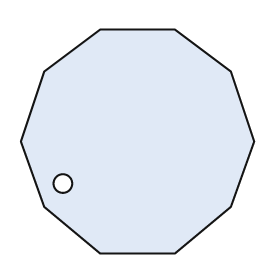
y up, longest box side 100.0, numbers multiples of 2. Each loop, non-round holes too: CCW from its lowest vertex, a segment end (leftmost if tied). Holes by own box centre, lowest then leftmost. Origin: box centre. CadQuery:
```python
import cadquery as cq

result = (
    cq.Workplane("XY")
    .moveTo(-16.0, -48.0)
    .lineTo(16.0, -48.0)
    .lineTo(40.0, -28.0)
    .lineTo(50.0, 0.0)
    .lineTo(40.0, 30.0)
    .lineTo(16.0, 48.0)
    .lineTo(-16.0, 48.0)
    .lineTo(-40.0, 30.0)
    .lineTo(-50.0, 0.0)
    .lineTo(-40.0, -28.0)
    .close()
    .moveTo(-32.0, -18.0)
    .circle(4.0)
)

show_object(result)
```